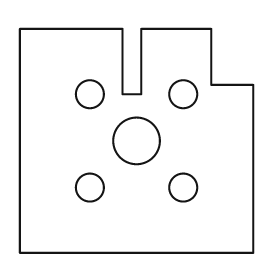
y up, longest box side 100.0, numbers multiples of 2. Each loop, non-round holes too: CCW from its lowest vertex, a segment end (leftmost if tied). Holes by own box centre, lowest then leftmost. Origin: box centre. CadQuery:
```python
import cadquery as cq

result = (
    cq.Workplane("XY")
    .moveTo(-50.0, -48.0)
    .lineTo(50.0, -48.0)
    .lineTo(50.0, 24.0)
    .lineTo(32.0, 24.0)
    .lineTo(32.0, 48.0)
    .lineTo(2.0, 48.0)
    .lineTo(2.0, 20.0)
    .lineTo(-6.0, 20.0)
    .lineTo(-6.0, 48.0)
    .lineTo(-50.0, 48.0)
    .close()
    .moveTo(-20.0, -20.0)
    .circle(6.0)
    .moveTo(20.0, -20.0)
    .circle(6.0)
    .moveTo(0.0, 0.0)
    .circle(10.0)
    .moveTo(-20.0, 20.0)
    .circle(6.0)
    .moveTo(20.0, 20.0)
    .circle(6.0)
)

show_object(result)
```